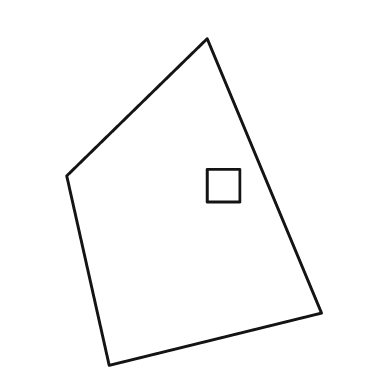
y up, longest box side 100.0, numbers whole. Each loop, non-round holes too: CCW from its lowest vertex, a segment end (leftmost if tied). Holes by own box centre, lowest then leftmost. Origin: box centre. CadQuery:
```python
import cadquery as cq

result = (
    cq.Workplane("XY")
    .moveTo(-26.0, -50.0)
    .lineTo(39.0, -34.0)
    .lineTo(4.0, 50.0)
    .lineTo(-39.0, 8.0)
    .close()
    .moveTo(4.0, 0.0)
    .lineTo(14.0, 0.0)
    .lineTo(14.0, 10.0)
    .lineTo(4.0, 10.0)
    .close()
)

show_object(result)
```